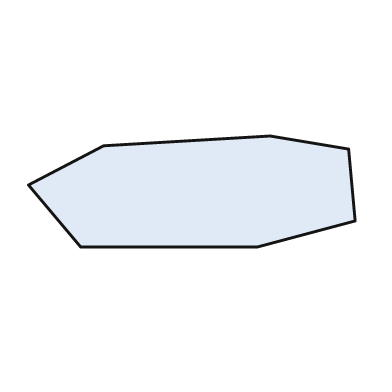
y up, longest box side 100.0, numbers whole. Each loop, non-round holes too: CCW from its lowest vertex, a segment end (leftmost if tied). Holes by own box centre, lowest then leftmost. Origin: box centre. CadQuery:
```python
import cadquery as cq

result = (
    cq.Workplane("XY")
    .moveTo(-34.0, -17.0)
    .lineTo(20.0, -17.0)
    .lineTo(50.0, -9.0)
    .lineTo(48.0, 13.0)
    .lineTo(24.0, 17.0)
    .lineTo(-27.0, 14.0)
    .lineTo(-50.0, 2.0)
    .close()
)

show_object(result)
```